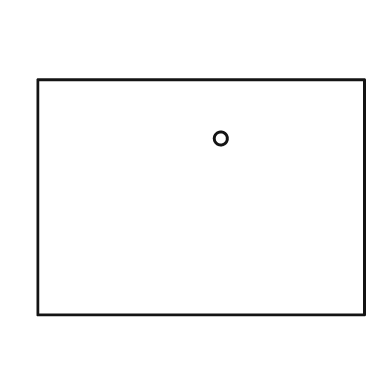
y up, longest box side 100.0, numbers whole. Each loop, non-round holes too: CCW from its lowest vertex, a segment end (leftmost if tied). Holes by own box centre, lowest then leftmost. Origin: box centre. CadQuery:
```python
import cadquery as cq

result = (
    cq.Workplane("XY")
    .moveTo(-50.0, -36.0)
    .lineTo(50.0, -36.0)
    .lineTo(50.0, 36.0)
    .lineTo(-50.0, 36.0)
    .close()
    .moveTo(6.0, 18.0)
    .circle(2.0)
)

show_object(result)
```